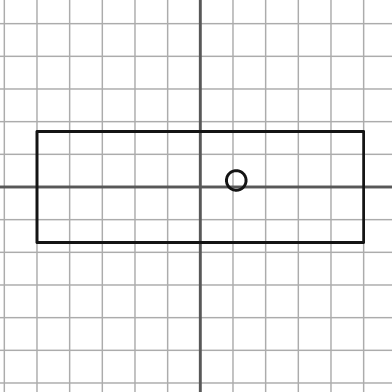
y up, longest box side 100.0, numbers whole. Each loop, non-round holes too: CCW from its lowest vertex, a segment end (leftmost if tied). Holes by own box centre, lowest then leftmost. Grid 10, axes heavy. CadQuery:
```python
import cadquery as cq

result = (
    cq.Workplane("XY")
    .moveTo(-50.0, -17.0)
    .lineTo(50.0, -17.0)
    .lineTo(50.0, 17.0)
    .lineTo(-50.0, 17.0)
    .close()
    .moveTo(11.0, 2.0)
    .circle(3.0)
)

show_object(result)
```